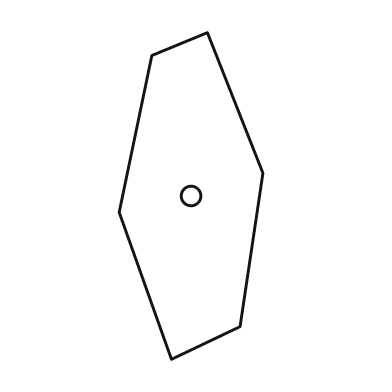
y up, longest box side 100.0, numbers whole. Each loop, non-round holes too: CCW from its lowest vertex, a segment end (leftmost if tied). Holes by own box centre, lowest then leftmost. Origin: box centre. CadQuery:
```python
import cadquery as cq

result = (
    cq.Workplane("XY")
    .moveTo(-6.0, -50.0)
    .lineTo(15.0, -40.0)
    .lineTo(22.0, 7.0)
    .lineTo(5.0, 50.0)
    .lineTo(-12.0, 43.0)
    .lineTo(-22.0, -5.0)
    .close()
    .moveTo(0.0, 0.0)
    .circle(3.0)
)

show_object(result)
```